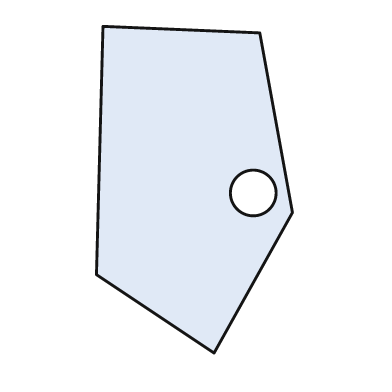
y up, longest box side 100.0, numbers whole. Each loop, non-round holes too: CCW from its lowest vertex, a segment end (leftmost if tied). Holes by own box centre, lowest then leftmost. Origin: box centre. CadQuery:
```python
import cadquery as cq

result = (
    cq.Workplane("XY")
    .moveTo(6.0, -50.0)
    .lineTo(30.0, -7.0)
    .lineTo(20.0, 48.0)
    .lineTo(-28.0, 50.0)
    .lineTo(-30.0, -26.0)
    .close()
    .moveTo(18.0, -1.0)
    .circle(7.0)
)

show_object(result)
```